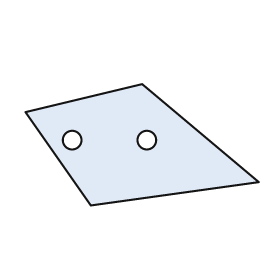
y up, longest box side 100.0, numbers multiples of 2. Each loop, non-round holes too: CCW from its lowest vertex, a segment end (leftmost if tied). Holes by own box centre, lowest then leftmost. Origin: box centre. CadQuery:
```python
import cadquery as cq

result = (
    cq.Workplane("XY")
    .moveTo(-22.0, -26.0)
    .lineTo(50.0, -16.0)
    .lineTo(0.0, 26.0)
    .lineTo(-50.0, 14.0)
    .close()
    .moveTo(-30.0, 2.0)
    .circle(4.0)
    .moveTo(2.0, 2.0)
    .circle(4.0)
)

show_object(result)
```